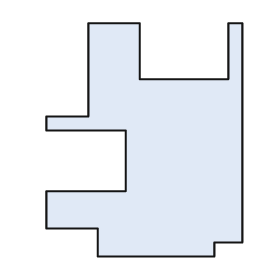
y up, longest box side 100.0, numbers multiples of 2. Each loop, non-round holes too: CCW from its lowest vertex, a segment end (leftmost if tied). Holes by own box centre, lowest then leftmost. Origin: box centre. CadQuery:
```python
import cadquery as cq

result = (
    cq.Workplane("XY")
    .moveTo(-20.0, -50.0)
    .lineTo(30.0, -50.0)
    .lineTo(30.0, -44.0)
    .lineTo(42.0, -44.0)
    .lineTo(42.0, 50.0)
    .lineTo(36.0, 50.0)
    .lineTo(36.0, 26.0)
    .lineTo(-2.0, 26.0)
    .lineTo(-2.0, 50.0)
    .lineTo(-24.0, 50.0)
    .lineTo(-24.0, 10.0)
    .lineTo(-42.0, 10.0)
    .lineTo(-42.0, 4.0)
    .lineTo(-8.0, 4.0)
    .lineTo(-8.0, -22.0)
    .lineTo(-42.0, -22.0)
    .lineTo(-42.0, -38.0)
    .lineTo(-20.0, -38.0)
    .close()
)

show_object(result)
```